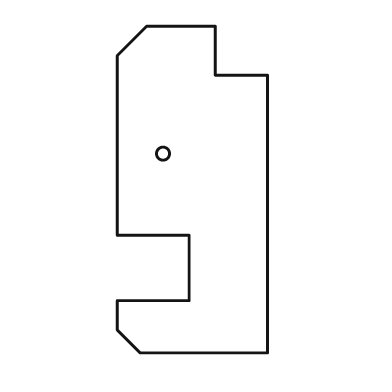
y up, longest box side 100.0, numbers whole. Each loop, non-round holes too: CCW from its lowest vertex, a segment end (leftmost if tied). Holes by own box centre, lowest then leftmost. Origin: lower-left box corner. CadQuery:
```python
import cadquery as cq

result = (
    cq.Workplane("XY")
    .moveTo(7.0, 0.0)
    .lineTo(46.0, 0.0)
    .lineTo(46.0, 85.0)
    .lineTo(30.0, 85.0)
    .lineTo(30.0, 100.0)
    .lineTo(9.0, 100.0)
    .lineTo(0.0, 91.0)
    .lineTo(0.0, 36.0)
    .lineTo(22.0, 36.0)
    .lineTo(22.0, 16.0)
    .lineTo(0.0, 16.0)
    .lineTo(0.0, 7.0)
    .close()
    .moveTo(14.0, 61.0)
    .circle(2.0)
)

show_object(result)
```